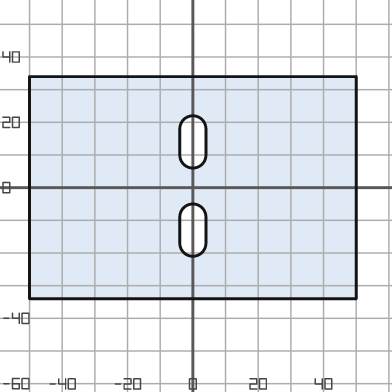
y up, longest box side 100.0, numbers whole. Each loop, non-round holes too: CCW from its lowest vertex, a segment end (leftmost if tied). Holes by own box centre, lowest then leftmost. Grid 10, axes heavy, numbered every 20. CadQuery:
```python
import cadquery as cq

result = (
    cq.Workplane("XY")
    .moveTo(-50.0, -34.0)
    .lineTo(50.0, -34.0)
    .lineTo(50.0, 34.0)
    .lineTo(-50.0, 34.0)
    .close()
    .moveTo(-4.0, -17.0)
    .threePointArc((0.0, -21.0), (4.0, -17.0))
    .lineTo(4.0, -9.0)
    .threePointArc((0.0, -5.0), (-4.0, -9.0))
    .close()
    .moveTo(-4.0, 10.0)
    .threePointArc((0.0, 6.0), (4.0, 10.0))
    .lineTo(4.0, 18.0)
    .threePointArc((0.0, 22.0), (-4.0, 18.0))
    .close()
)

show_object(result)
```